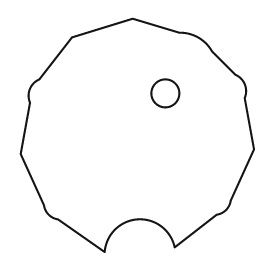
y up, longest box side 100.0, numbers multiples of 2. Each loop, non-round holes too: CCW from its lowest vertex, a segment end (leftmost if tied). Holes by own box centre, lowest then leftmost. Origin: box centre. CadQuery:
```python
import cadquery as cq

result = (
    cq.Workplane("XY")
    .moveTo(-14.0, -50.0)
    .threePointArc((0.0, -36.0), (16.0, -48.0))
    .lineTo(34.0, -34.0)
    .threePointArc((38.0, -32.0), (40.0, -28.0))
    .lineTo(50.0, -6.0)
    .lineTo(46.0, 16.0)
    .threePointArc((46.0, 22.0), (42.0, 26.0))
    .lineTo(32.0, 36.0)
    .threePointArc((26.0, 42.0), (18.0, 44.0))
    .lineTo(-2.0, 50.0)
    .lineTo(-28.0, 42.0)
    .lineTo(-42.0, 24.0)
    .threePointArc((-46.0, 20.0), (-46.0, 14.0))
    .lineTo(-50.0, -8.0)
    .lineTo(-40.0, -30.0)
    .threePointArc((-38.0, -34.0), (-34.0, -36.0))
    .close()
    .moveTo(12.0, 18.0)
    .circle(6.0)
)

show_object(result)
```